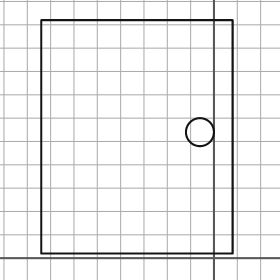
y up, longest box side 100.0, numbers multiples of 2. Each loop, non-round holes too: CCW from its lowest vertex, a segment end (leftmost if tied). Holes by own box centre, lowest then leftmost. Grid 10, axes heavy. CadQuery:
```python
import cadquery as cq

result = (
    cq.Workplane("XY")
    .moveTo(-74.0, 2.0)
    .lineTo(8.0, 2.0)
    .lineTo(8.0, 102.0)
    .lineTo(-74.0, 102.0)
    .close()
    .moveTo(-6.0, 54.0)
    .circle(6.0)
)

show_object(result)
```